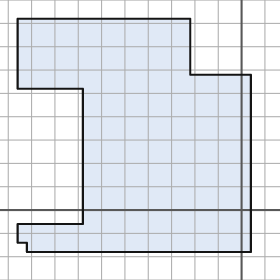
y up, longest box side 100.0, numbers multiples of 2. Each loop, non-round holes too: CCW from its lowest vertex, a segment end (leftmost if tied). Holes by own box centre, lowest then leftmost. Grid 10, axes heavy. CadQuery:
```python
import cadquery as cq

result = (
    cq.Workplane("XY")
    .moveTo(-92.0, -18.0)
    .lineTo(4.0, -18.0)
    .lineTo(4.0, 58.0)
    .lineTo(-22.0, 58.0)
    .lineTo(-22.0, 82.0)
    .lineTo(-96.0, 82.0)
    .lineTo(-96.0, 52.0)
    .lineTo(-68.0, 52.0)
    .lineTo(-68.0, -6.0)
    .lineTo(-96.0, -6.0)
    .lineTo(-96.0, -14.0)
    .lineTo(-92.0, -14.0)
    .close()
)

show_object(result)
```